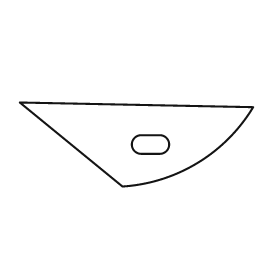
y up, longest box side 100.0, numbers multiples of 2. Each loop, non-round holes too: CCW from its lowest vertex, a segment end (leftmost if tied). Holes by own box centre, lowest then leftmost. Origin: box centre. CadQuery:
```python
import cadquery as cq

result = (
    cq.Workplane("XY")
    .moveTo(-6.0, -18.0)
    .threePointArc((26.0, -8.0), (50.0, 16.0))
    .lineTo(-50.0, 18.0)
    .close()
    .moveTo(2.0, -4.0)
    .lineTo(10.0, -4.0)
    .threePointArc((14.0, 0.0), (10.0, 4.0))
    .lineTo(2.0, 4.0)
    .threePointArc((-2.0, 0.0), (2.0, -4.0))
    .close()
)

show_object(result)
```